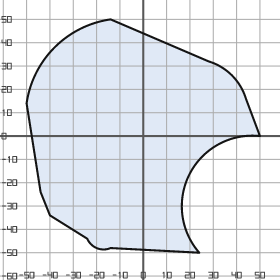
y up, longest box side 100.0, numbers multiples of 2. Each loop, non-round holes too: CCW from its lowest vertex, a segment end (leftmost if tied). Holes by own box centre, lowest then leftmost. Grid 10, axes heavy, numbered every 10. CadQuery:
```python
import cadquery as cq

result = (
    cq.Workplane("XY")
    .moveTo(24.0, -50.0)
    .threePointArc((20.0, -16.0), (50.0, 0.0))
    .lineTo(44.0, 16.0)
    .threePointArc((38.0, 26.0), (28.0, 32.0))
    .lineTo(-14.0, 50.0)
    .threePointArc((-38.0, 38.0), (-50.0, 14.0))
    .lineTo(-44.0, -24.0)
    .lineTo(-40.0, -34.0)
    .lineTo(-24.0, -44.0)
    .threePointArc((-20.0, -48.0), (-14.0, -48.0))
    .close()
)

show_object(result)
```